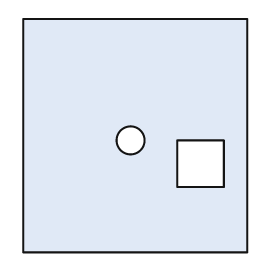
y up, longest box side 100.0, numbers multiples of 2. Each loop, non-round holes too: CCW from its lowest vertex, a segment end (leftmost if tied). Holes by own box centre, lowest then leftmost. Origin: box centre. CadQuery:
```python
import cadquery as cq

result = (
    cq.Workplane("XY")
    .moveTo(-48.0, -50.0)
    .lineTo(48.0, -50.0)
    .lineTo(48.0, 50.0)
    .lineTo(-48.0, 50.0)
    .close()
    .moveTo(18.0, -22.0)
    .lineTo(38.0, -22.0)
    .lineTo(38.0, -2.0)
    .lineTo(18.0, -2.0)
    .close()
    .moveTo(-2.0, -2.0)
    .circle(6.0)
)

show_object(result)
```